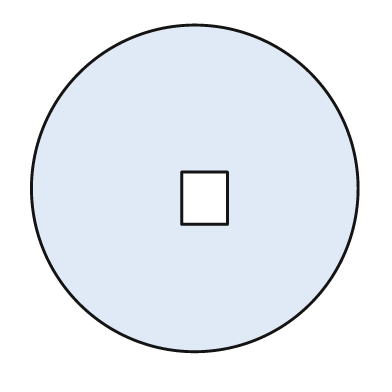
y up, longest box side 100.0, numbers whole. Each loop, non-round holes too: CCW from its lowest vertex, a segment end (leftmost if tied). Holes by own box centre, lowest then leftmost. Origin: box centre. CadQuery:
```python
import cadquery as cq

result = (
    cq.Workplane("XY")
    .moveTo(0.0, 0.0)
    .circle(50.0)
    .moveTo(-4.0, -11.0)
    .lineTo(10.0, -11.0)
    .lineTo(10.0, 5.0)
    .lineTo(-4.0, 5.0)
    .close()
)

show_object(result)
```